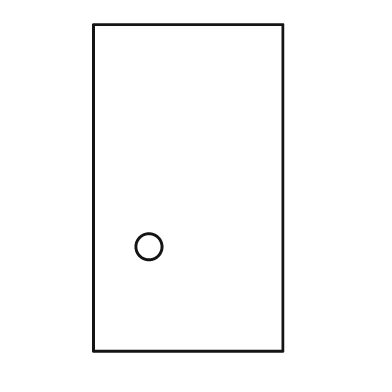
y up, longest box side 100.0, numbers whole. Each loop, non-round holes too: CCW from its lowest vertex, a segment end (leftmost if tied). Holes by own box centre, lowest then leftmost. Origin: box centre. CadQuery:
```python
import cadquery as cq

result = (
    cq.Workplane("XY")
    .moveTo(-29.0, -50.0)
    .lineTo(29.0, -50.0)
    .lineTo(29.0, 50.0)
    .lineTo(-29.0, 50.0)
    .close()
    .moveTo(-12.0, -18.0)
    .circle(4.0)
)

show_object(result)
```